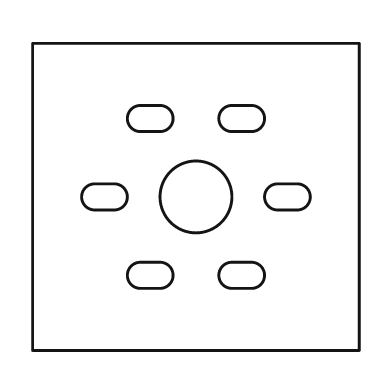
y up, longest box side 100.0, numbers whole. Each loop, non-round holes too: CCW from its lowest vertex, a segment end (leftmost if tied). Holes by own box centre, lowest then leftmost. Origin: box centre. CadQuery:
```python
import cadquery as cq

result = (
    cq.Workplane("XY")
    .moveTo(-50.0, -47.0)
    .lineTo(50.0, -47.0)
    .lineTo(50.0, 47.0)
    .lineTo(-50.0, 47.0)
    .close()
    .moveTo(-17.0, -28.0)
    .lineTo(-11.0, -28.0)
    .threePointArc((-7.0, -24.0), (-11.0, -20.0))
    .lineTo(-17.0, -20.0)
    .threePointArc((-21.0, -24.0), (-17.0, -28.0))
    .close()
    .moveTo(11.0, -28.0)
    .lineTo(17.0, -28.0)
    .threePointArc((21.0, -24.0), (17.0, -20.0))
    .lineTo(11.0, -20.0)
    .threePointArc((7.0, -24.0), (11.0, -28.0))
    .close()
    .moveTo(-31.0, -4.0)
    .lineTo(-25.0, -4.0)
    .threePointArc((-21.0, 0.0), (-25.0, 4.0))
    .lineTo(-31.0, 4.0)
    .threePointArc((-35.0, 0.0), (-31.0, -4.0))
    .close()
    .moveTo(0.0, 0.0)
    .circle(11.0)
    .moveTo(25.0, -4.0)
    .lineTo(31.0, -4.0)
    .threePointArc((35.0, 0.0), (31.0, 4.0))
    .lineTo(25.0, 4.0)
    .threePointArc((21.0, 0.0), (25.0, -4.0))
    .close()
    .moveTo(-17.0, 20.0)
    .lineTo(-11.0, 20.0)
    .threePointArc((-7.0, 24.0), (-11.0, 28.0))
    .lineTo(-17.0, 28.0)
    .threePointArc((-21.0, 24.0), (-17.0, 20.0))
    .close()
    .moveTo(11.0, 20.0)
    .lineTo(17.0, 20.0)
    .threePointArc((21.0, 24.0), (17.0, 28.0))
    .lineTo(11.0, 28.0)
    .threePointArc((7.0, 24.0), (11.0, 20.0))
    .close()
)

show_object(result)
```